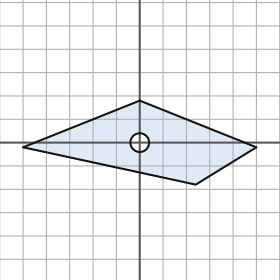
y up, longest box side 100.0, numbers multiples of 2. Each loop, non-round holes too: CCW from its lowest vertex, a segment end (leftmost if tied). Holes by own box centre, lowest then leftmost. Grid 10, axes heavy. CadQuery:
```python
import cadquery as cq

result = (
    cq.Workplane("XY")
    .moveTo(24.0, -18.0)
    .lineTo(50.0, -2.0)
    .lineTo(0.0, 18.0)
    .lineTo(-50.0, -2.0)
    .close()
    .moveTo(0.0, 0.0)
    .circle(4.0)
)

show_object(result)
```